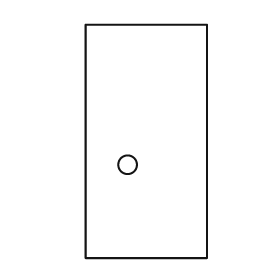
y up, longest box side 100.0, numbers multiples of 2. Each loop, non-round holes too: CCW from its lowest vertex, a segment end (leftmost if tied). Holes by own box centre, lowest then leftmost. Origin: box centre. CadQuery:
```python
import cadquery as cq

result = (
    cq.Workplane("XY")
    .moveTo(-26.0, -50.0)
    .lineTo(26.0, -50.0)
    .lineTo(26.0, 50.0)
    .lineTo(-26.0, 50.0)
    .close()
    .moveTo(-8.0, -10.0)
    .circle(4.0)
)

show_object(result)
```